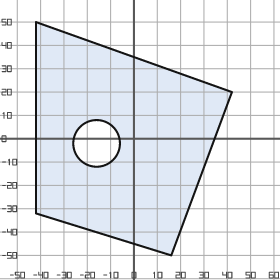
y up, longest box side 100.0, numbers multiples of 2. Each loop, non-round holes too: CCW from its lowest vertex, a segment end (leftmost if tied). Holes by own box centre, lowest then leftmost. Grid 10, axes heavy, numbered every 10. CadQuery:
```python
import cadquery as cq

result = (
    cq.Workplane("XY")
    .moveTo(16.0, -50.0)
    .lineTo(42.0, 20.0)
    .lineTo(-42.0, 50.0)
    .lineTo(-42.0, -32.0)
    .close()
    .moveTo(-16.0, -2.0)
    .circle(10.0)
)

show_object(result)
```